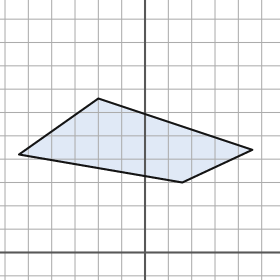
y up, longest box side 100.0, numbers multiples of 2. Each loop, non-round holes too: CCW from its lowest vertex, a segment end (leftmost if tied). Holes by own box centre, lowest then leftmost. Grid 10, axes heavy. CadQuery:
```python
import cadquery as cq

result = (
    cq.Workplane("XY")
    .moveTo(16.0, 30.0)
    .lineTo(46.0, 44.0)
    .lineTo(-20.0, 66.0)
    .lineTo(-54.0, 42.0)
    .close()
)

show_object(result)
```